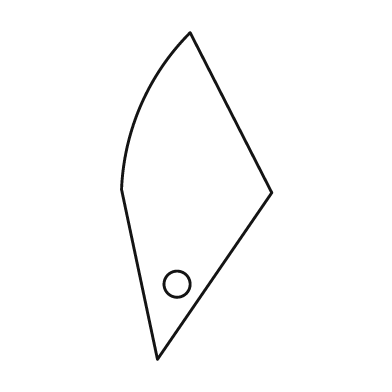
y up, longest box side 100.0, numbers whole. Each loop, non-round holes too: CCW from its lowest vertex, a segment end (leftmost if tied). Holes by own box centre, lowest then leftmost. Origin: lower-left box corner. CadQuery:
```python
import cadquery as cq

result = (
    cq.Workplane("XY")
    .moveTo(11.0, 0.0)
    .lineTo(46.0, 51.0)
    .lineTo(21.0, 100.0)
    .threePointArc((6.0, 78.0), (0.0, 52.0))
    .close()
    .moveTo(17.0, 23.0)
    .circle(4.0)
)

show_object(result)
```